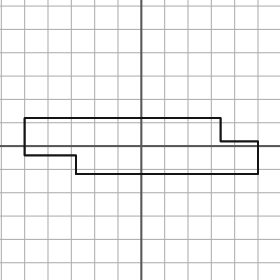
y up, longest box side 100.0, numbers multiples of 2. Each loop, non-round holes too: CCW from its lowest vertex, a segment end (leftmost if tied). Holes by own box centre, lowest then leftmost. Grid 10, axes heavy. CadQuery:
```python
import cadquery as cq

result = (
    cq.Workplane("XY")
    .moveTo(-28.0, -12.0)
    .lineTo(50.0, -12.0)
    .lineTo(50.0, 2.0)
    .lineTo(34.0, 2.0)
    .lineTo(34.0, 12.0)
    .lineTo(-50.0, 12.0)
    .lineTo(-50.0, -4.0)
    .lineTo(-28.0, -4.0)
    .close()
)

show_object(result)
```